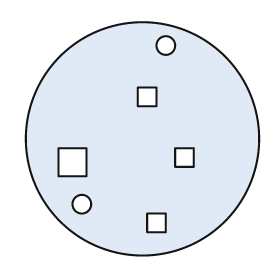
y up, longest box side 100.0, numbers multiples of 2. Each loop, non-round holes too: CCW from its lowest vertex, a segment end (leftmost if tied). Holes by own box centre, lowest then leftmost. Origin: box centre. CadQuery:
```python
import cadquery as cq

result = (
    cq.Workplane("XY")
    .moveTo(0.0, 0.0)
    .circle(50.0)
    .moveTo(2.0, -40.0)
    .lineTo(10.0, -40.0)
    .lineTo(10.0, -32.0)
    .lineTo(2.0, -32.0)
    .close()
    .moveTo(-26.0, -28.0)
    .circle(4.0)
    .moveTo(-36.0, -16.0)
    .lineTo(-24.0, -16.0)
    .lineTo(-24.0, -4.0)
    .lineTo(-36.0, -4.0)
    .close()
    .moveTo(14.0, -12.0)
    .lineTo(22.0, -12.0)
    .lineTo(22.0, -4.0)
    .lineTo(14.0, -4.0)
    .close()
    .moveTo(-2.0, 14.0)
    .lineTo(6.0, 14.0)
    .lineTo(6.0, 22.0)
    .lineTo(-2.0, 22.0)
    .close()
    .moveTo(10.0, 40.0)
    .circle(4.0)
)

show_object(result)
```